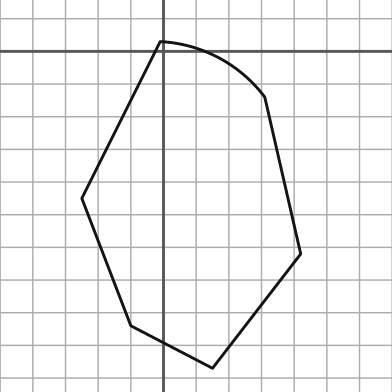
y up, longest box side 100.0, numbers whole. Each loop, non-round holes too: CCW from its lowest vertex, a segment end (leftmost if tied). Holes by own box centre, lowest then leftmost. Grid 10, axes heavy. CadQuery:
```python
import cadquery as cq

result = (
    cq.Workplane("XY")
    .moveTo(15.0, -97.0)
    .lineTo(42.0, -62.0)
    .lineTo(31.0, -14.0)
    .threePointArc((17.0, -2.0), (-1.0, 3.0))
    .lineTo(-25.0, -45.0)
    .lineTo(-10.0, -84.0)
    .close()
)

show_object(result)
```